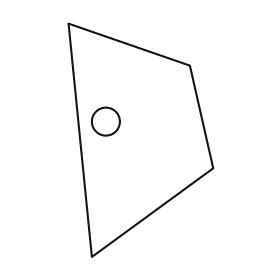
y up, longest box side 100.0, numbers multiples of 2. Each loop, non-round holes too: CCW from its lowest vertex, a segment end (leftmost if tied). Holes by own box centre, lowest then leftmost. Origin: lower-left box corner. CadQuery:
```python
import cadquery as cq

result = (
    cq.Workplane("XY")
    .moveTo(10.0, 0.0)
    .lineTo(62.0, 38.0)
    .lineTo(52.0, 82.0)
    .lineTo(0.0, 100.0)
    .close()
    .moveTo(16.0, 58.0)
    .circle(6.0)
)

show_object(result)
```